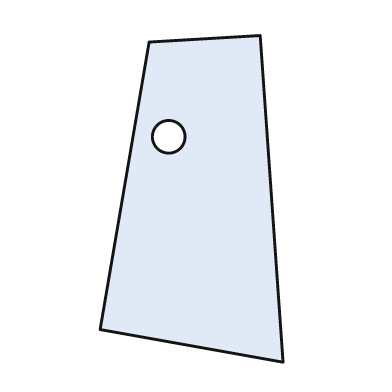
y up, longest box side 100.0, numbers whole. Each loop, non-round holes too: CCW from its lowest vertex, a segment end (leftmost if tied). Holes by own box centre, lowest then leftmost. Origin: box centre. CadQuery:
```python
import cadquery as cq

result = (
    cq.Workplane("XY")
    .moveTo(28.0, -50.0)
    .lineTo(21.0, 50.0)
    .lineTo(-13.0, 48.0)
    .lineTo(-28.0, -40.0)
    .close()
    .moveTo(-7.0, 19.0)
    .circle(5.0)
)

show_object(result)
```